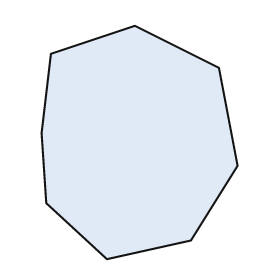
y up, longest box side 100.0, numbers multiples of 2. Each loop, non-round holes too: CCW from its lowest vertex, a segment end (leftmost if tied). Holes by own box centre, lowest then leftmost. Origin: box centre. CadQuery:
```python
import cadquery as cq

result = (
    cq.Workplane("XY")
    .moveTo(-14.0, -50.0)
    .lineTo(22.0, -42.0)
    .lineTo(42.0, -10.0)
    .lineTo(34.0, 32.0)
    .lineTo(-2.0, 50.0)
    .lineTo(-38.0, 38.0)
    .lineTo(-42.0, 4.0)
    .lineTo(-40.0, -26.0)
    .close()
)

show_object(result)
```